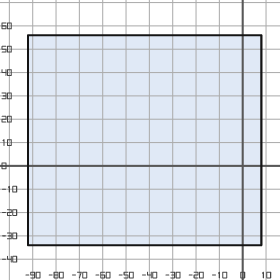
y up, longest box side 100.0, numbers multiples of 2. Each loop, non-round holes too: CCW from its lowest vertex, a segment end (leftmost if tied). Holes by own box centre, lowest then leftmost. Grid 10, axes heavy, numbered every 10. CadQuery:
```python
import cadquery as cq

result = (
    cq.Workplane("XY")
    .moveTo(-92.0, -34.0)
    .lineTo(8.0, -34.0)
    .lineTo(8.0, 56.0)
    .lineTo(-92.0, 56.0)
    .close()
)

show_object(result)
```